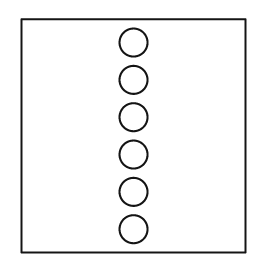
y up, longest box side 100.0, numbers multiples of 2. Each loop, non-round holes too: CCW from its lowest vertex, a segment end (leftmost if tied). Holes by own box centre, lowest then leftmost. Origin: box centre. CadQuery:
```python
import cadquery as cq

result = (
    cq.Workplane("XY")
    .moveTo(-48.0, -50.0)
    .lineTo(48.0, -50.0)
    .lineTo(48.0, 50.0)
    .lineTo(-48.0, 50.0)
    .close()
    .moveTo(0.0, -40.0)
    .circle(6.0)
    .moveTo(0.0, -24.0)
    .circle(6.0)
    .moveTo(0.0, -8.0)
    .circle(6.0)
    .moveTo(0.0, 8.0)
    .circle(6.0)
    .moveTo(0.0, 24.0)
    .circle(6.0)
    .moveTo(0.0, 40.0)
    .circle(6.0)
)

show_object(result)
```